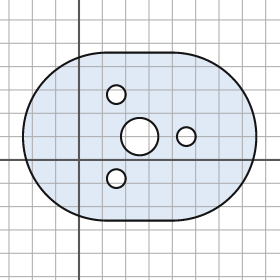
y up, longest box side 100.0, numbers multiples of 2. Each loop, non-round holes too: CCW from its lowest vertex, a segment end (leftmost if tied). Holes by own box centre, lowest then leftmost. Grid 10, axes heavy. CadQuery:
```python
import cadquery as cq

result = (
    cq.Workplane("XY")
    .moveTo(12.0, -26.0)
    .lineTo(40.0, -26.0)
    .threePointArc((76.0, 10.0), (40.0, 46.0))
    .lineTo(12.0, 46.0)
    .threePointArc((-24.0, 10.0), (12.0, -26.0))
    .close()
    .moveTo(16.0, -8.0)
    .circle(4.0)
    .moveTo(26.0, 10.0)
    .circle(8.0)
    .moveTo(46.0, 10.0)
    .circle(4.0)
    .moveTo(16.0, 28.0)
    .circle(4.0)
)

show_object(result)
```